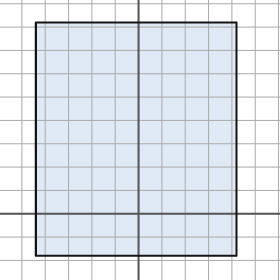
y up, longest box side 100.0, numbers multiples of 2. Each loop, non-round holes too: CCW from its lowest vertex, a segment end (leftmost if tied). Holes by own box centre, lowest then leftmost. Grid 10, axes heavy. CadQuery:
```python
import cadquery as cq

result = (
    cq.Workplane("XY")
    .moveTo(-44.0, -18.0)
    .lineTo(42.0, -18.0)
    .lineTo(42.0, 82.0)
    .lineTo(-44.0, 82.0)
    .close()
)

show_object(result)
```